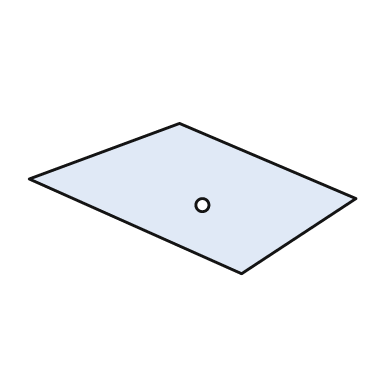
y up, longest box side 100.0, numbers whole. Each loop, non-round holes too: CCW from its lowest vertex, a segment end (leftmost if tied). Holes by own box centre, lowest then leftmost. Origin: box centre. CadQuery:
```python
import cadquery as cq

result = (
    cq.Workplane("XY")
    .moveTo(15.0, -23.0)
    .lineTo(50.0, 0.0)
    .lineTo(-4.0, 23.0)
    .lineTo(-50.0, 6.0)
    .close()
    .moveTo(3.0, -2.0)
    .circle(2.0)
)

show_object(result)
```